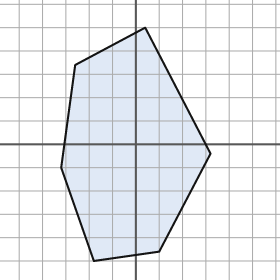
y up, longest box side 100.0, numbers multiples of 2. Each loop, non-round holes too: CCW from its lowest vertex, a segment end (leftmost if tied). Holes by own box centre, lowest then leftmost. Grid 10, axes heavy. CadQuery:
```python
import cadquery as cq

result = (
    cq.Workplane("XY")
    .moveTo(-18.0, -50.0)
    .lineTo(10.0, -46.0)
    .lineTo(32.0, -4.0)
    .lineTo(4.0, 50.0)
    .lineTo(-26.0, 34.0)
    .lineTo(-32.0, -10.0)
    .close()
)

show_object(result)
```